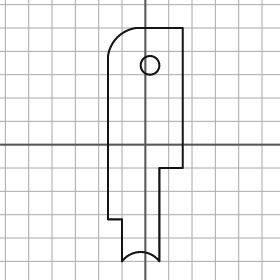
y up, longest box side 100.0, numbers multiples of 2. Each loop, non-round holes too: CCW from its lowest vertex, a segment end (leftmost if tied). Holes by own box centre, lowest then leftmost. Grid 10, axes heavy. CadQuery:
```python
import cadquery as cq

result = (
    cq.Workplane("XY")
    .moveTo(-10.0, -50.0)
    .threePointArc((-2.0, -46.0), (6.0, -50.0))
    .lineTo(6.0, -10.0)
    .lineTo(16.0, -10.0)
    .lineTo(16.0, 50.0)
    .lineTo(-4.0, 50.0)
    .threePointArc((-12.0, 46.0), (-16.0, 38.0))
    .lineTo(-16.0, -32.0)
    .lineTo(-10.0, -32.0)
    .close()
    .moveTo(2.0, 34.0)
    .circle(4.0)
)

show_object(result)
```